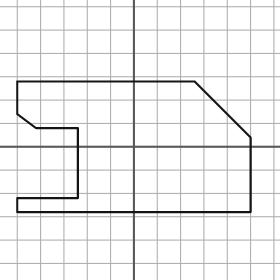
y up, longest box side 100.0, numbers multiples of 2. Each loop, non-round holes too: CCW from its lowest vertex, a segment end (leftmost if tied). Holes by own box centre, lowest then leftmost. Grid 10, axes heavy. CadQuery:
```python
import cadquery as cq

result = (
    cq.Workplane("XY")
    .moveTo(-50.0, -28.0)
    .lineTo(50.0, -28.0)
    .lineTo(50.0, 4.0)
    .lineTo(26.0, 28.0)
    .lineTo(-50.0, 28.0)
    .lineTo(-50.0, 14.0)
    .lineTo(-42.0, 8.0)
    .lineTo(-24.0, 8.0)
    .lineTo(-24.0, -22.0)
    .lineTo(-50.0, -22.0)
    .close()
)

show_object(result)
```